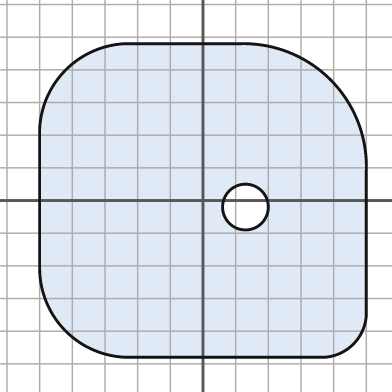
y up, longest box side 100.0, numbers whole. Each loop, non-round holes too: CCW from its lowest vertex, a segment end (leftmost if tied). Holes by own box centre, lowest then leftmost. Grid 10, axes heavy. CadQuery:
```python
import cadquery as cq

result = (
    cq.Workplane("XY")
    .moveTo(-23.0, -48.0)
    .lineTo(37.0, -48.0)
    .threePointArc((46.0, -44.0), (50.0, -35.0))
    .lineTo(50.0, 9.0)
    .threePointArc((39.0, 37.0), (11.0, 48.0))
    .lineTo(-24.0, 48.0)
    .threePointArc((-42.0, 40.0), (-50.0, 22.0))
    .lineTo(-50.0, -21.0)
    .threePointArc((-42.0, -40.0), (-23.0, -48.0))
    .close()
    .moveTo(13.0, -2.0)
    .circle(7.0)
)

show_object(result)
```